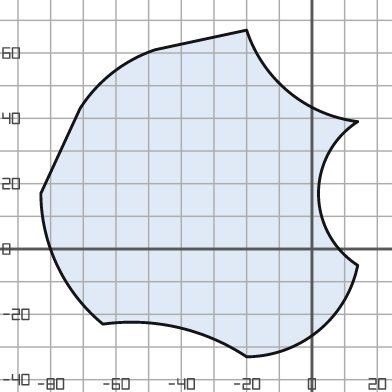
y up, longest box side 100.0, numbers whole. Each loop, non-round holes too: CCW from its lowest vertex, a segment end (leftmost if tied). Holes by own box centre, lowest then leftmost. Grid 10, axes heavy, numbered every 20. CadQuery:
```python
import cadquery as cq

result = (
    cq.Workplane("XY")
    .moveTo(-20.0, -33.0)
    .threePointArc((2.0, -25.0), (14.0, -5.0))
    .threePointArc((2.0, 17.0), (14.0, 39.0))
    .threePointArc((-7.0, 48.0), (-20.0, 67.0))
    .lineTo(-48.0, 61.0)
    .threePointArc((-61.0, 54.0), (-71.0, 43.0))
    .lineTo(-83.0, 17.0)
    .threePointArc((-78.0, -5.0), (-64.0, -23.0))
    .threePointArc((-41.0, -24.0), (-20.0, -33.0))
    .close()
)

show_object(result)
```